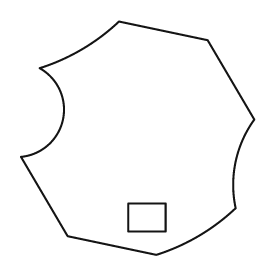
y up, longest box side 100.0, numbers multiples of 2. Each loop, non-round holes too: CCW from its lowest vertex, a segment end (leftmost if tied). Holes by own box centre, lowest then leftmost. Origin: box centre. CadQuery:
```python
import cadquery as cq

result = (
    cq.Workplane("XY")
    .moveTo(8.0, -50.0)
    .threePointArc((26.0, -42.0), (42.0, -30.0))
    .threePointArc((42.0, -10.0), (50.0, 8.0))
    .lineTo(30.0, 42.0)
    .lineTo(-8.0, 50.0)
    .threePointArc((-24.0, 38.0), (-42.0, 30.0))
    .threePointArc((-32.0, 8.0), (-50.0, -8.0))
    .lineTo(-30.0, -42.0)
    .close()
    .moveTo(-4.0, -40.0)
    .lineTo(12.0, -40.0)
    .lineTo(12.0, -28.0)
    .lineTo(-4.0, -28.0)
    .close()
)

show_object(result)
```